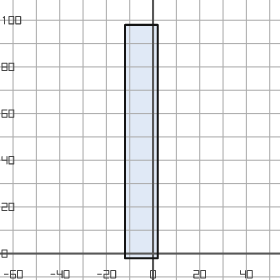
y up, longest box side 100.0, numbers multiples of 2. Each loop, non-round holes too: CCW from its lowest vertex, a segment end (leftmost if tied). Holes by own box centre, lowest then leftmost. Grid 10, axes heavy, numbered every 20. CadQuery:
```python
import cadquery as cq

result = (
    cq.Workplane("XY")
    .moveTo(-12.0, -2.0)
    .lineTo(2.0, -2.0)
    .lineTo(2.0, 98.0)
    .lineTo(-12.0, 98.0)
    .close()
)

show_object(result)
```